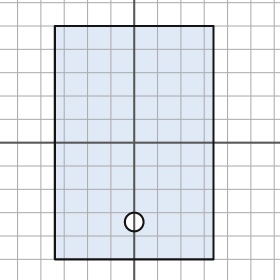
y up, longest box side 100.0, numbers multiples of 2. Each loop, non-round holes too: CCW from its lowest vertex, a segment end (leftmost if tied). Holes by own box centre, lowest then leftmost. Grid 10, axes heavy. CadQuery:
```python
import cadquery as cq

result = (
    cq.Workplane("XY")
    .moveTo(-34.0, -50.0)
    .lineTo(34.0, -50.0)
    .lineTo(34.0, 50.0)
    .lineTo(-34.0, 50.0)
    .close()
    .moveTo(0.0, -34.0)
    .circle(4.0)
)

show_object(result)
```